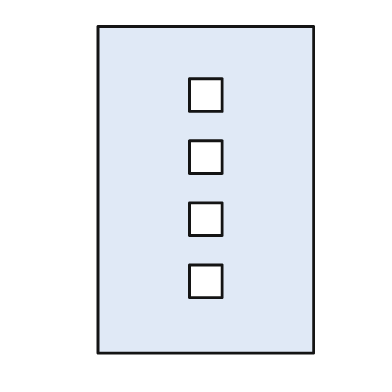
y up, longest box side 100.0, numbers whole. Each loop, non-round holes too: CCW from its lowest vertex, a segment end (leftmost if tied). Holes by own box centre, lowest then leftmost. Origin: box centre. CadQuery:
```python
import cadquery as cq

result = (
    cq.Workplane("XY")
    .moveTo(-33.0, -50.0)
    .lineTo(33.0, -50.0)
    .lineTo(33.0, 50.0)
    .lineTo(-33.0, 50.0)
    .close()
    .moveTo(-5.0, -33.0)
    .lineTo(5.0, -33.0)
    .lineTo(5.0, -23.0)
    .lineTo(-5.0, -23.0)
    .close()
    .moveTo(-5.0, -14.0)
    .lineTo(5.0, -14.0)
    .lineTo(5.0, -4.0)
    .lineTo(-5.0, -4.0)
    .close()
    .moveTo(-5.0, 5.0)
    .lineTo(5.0, 5.0)
    .lineTo(5.0, 15.0)
    .lineTo(-5.0, 15.0)
    .close()
    .moveTo(-5.0, 24.0)
    .lineTo(5.0, 24.0)
    .lineTo(5.0, 34.0)
    .lineTo(-5.0, 34.0)
    .close()
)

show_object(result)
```